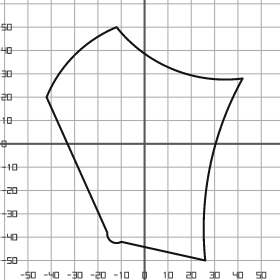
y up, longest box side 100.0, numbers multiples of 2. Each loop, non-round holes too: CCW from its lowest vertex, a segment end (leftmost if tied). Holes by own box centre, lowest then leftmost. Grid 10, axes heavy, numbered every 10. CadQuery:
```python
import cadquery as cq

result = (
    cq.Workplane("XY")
    .moveTo(26.0, -50.0)
    .threePointArc((28.0, -10.0), (42.0, 28.0))
    .threePointArc((12.0, 32.0), (-12.0, 50.0))
    .threePointArc((-30.0, 38.0), (-42.0, 20.0))
    .lineTo(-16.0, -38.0)
    .threePointArc((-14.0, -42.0), (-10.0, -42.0))
    .close()
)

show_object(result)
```